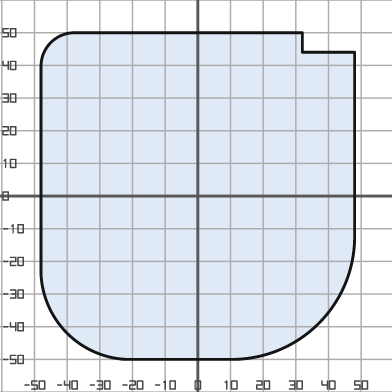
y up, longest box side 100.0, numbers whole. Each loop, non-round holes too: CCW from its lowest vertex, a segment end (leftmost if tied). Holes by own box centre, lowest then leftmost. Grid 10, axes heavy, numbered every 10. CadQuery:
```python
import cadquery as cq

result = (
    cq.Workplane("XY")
    .moveTo(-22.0, -50.0)
    .lineTo(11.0, -50.0)
    .threePointArc((37.0, -39.0), (48.0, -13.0))
    .lineTo(48.0, 44.0)
    .lineTo(32.0, 44.0)
    .lineTo(32.0, 50.0)
    .lineTo(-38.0, 50.0)
    .threePointArc((-45.0, 47.0), (-48.0, 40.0))
    .lineTo(-48.0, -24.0)
    .threePointArc((-40.0, -42.0), (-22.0, -50.0))
    .close()
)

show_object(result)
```